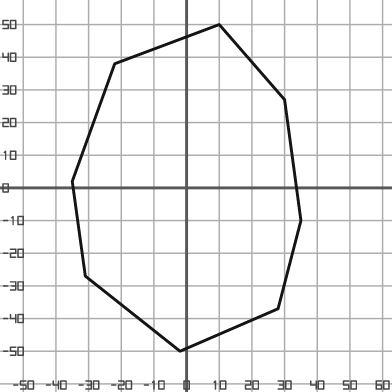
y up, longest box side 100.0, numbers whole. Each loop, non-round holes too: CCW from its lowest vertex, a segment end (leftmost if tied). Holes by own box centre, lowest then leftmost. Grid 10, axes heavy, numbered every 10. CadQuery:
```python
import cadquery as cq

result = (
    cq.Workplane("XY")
    .moveTo(-2.0, -50.0)
    .lineTo(28.0, -37.0)
    .lineTo(35.0, -10.0)
    .lineTo(30.0, 27.0)
    .lineTo(10.0, 50.0)
    .lineTo(-22.0, 38.0)
    .lineTo(-35.0, 2.0)
    .lineTo(-31.0, -27.0)
    .close()
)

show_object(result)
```